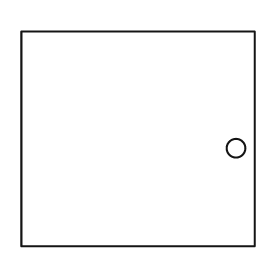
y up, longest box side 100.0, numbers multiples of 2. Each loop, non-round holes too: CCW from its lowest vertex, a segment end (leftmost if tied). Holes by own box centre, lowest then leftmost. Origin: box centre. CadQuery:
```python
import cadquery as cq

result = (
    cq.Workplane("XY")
    .moveTo(-50.0, -46.0)
    .lineTo(50.0, -46.0)
    .lineTo(50.0, 46.0)
    .lineTo(-50.0, 46.0)
    .close()
    .moveTo(42.0, -4.0)
    .circle(4.0)
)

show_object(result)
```